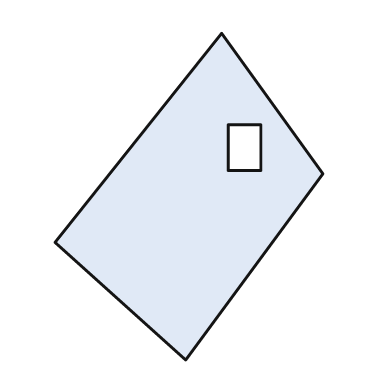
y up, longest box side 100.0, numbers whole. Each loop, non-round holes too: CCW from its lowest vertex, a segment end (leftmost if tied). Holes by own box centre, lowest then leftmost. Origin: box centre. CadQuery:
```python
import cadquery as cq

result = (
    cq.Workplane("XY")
    .moveTo(-1.0, -50.0)
    .lineTo(41.0, 7.0)
    .lineTo(10.0, 50.0)
    .lineTo(-41.0, -14.0)
    .close()
    .moveTo(12.0, 8.0)
    .lineTo(22.0, 8.0)
    .lineTo(22.0, 22.0)
    .lineTo(12.0, 22.0)
    .close()
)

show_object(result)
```